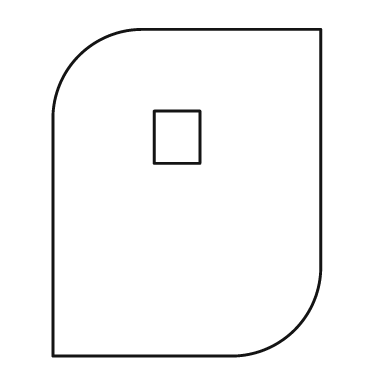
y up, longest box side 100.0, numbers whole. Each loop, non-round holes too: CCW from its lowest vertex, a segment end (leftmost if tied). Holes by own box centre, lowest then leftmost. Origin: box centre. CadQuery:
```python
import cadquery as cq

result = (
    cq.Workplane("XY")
    .moveTo(-41.0, -50.0)
    .lineTo(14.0, -50.0)
    .threePointArc((33.0, -42.0), (41.0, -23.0))
    .lineTo(41.0, 50.0)
    .lineTo(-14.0, 50.0)
    .threePointArc((-33.0, 42.0), (-41.0, 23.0))
    .close()
    .moveTo(-10.0, 9.0)
    .lineTo(4.0, 9.0)
    .lineTo(4.0, 25.0)
    .lineTo(-10.0, 25.0)
    .close()
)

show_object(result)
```